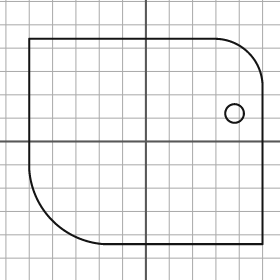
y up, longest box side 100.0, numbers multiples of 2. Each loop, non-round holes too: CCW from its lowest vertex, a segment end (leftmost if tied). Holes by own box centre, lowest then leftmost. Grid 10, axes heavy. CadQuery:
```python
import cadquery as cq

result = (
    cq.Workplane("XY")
    .moveTo(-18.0, -44.0)
    .lineTo(50.0, -44.0)
    .lineTo(50.0, 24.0)
    .threePointArc((44.0, 38.0), (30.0, 44.0))
    .lineTo(-50.0, 44.0)
    .lineTo(-50.0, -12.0)
    .threePointArc((-40.0, -34.0), (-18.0, -44.0))
    .close()
    .moveTo(38.0, 12.0)
    .circle(4.0)
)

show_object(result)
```